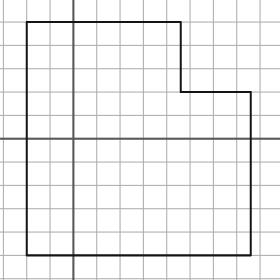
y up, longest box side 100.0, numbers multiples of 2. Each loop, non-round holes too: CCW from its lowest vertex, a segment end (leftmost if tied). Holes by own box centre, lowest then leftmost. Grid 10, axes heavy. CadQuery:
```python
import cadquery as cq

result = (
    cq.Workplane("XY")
    .moveTo(-20.0, -50.0)
    .lineTo(76.0, -50.0)
    .lineTo(76.0, 20.0)
    .lineTo(46.0, 20.0)
    .lineTo(46.0, 50.0)
    .lineTo(-20.0, 50.0)
    .close()
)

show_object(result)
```